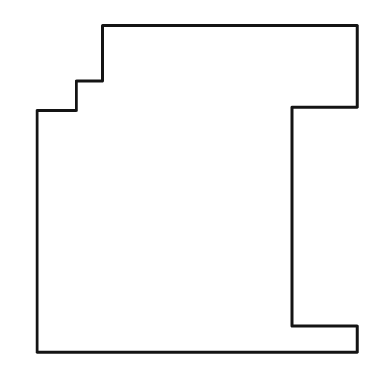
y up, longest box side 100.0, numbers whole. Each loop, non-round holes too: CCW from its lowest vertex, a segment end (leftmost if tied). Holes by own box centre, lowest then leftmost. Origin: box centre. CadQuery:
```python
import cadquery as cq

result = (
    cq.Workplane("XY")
    .moveTo(-49.0, -50.0)
    .lineTo(49.0, -50.0)
    .lineTo(49.0, -42.0)
    .lineTo(29.0, -42.0)
    .lineTo(29.0, 25.0)
    .lineTo(49.0, 25.0)
    .lineTo(49.0, 50.0)
    .lineTo(-29.0, 50.0)
    .lineTo(-29.0, 33.0)
    .lineTo(-37.0, 33.0)
    .lineTo(-37.0, 24.0)
    .lineTo(-49.0, 24.0)
    .close()
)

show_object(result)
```